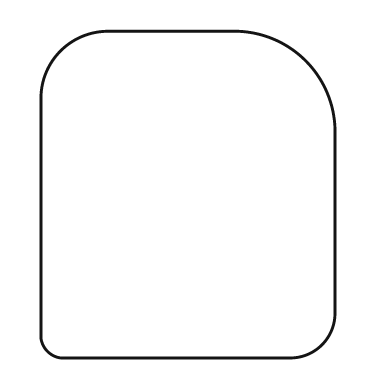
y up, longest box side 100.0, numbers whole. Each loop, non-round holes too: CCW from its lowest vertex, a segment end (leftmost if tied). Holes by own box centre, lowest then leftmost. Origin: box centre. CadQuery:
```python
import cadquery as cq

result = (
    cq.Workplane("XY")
    .moveTo(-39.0, -50.0)
    .lineTo(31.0, -50.0)
    .threePointArc((41.0, -46.0), (45.0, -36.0))
    .lineTo(45.0, 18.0)
    .threePointArc((36.0, 41.0), (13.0, 50.0))
    .lineTo(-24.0, 50.0)
    .threePointArc((-39.0, 44.0), (-45.0, 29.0))
    .lineTo(-45.0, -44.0)
    .threePointArc((-43.0, -48.0), (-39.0, -50.0))
    .close()
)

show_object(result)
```